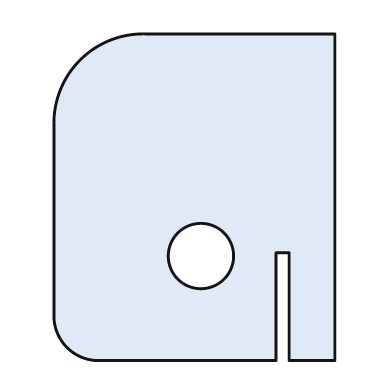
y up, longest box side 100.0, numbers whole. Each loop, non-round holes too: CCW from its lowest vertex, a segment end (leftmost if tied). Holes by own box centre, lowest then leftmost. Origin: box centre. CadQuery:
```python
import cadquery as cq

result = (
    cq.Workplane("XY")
    .moveTo(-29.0, -50.0)
    .lineTo(25.0, -50.0)
    .lineTo(25.0, -17.0)
    .lineTo(29.0, -17.0)
    .lineTo(29.0, -50.0)
    .lineTo(43.0, -50.0)
    .lineTo(43.0, 50.0)
    .lineTo(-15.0, 50.0)
    .threePointArc((-35.0, 42.0), (-43.0, 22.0))
    .lineTo(-43.0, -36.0)
    .threePointArc((-39.0, -46.0), (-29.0, -50.0))
    .close()
    .moveTo(2.0, -18.0)
    .circle(10.0)
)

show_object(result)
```